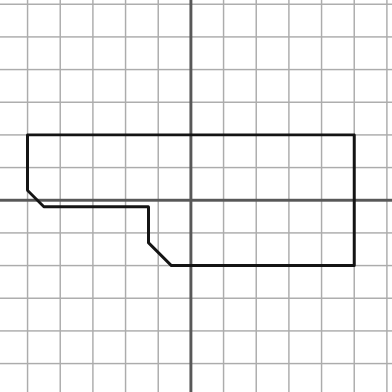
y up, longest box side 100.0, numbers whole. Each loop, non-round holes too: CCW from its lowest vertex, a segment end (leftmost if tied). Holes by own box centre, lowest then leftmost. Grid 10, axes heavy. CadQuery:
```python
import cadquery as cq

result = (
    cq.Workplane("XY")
    .moveTo(-6.0, -20.0)
    .lineTo(50.0, -20.0)
    .lineTo(50.0, 20.0)
    .lineTo(-50.0, 20.0)
    .lineTo(-50.0, 3.0)
    .lineTo(-45.0, -2.0)
    .lineTo(-13.0, -2.0)
    .lineTo(-13.0, -13.0)
    .close()
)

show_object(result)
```